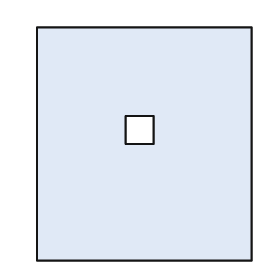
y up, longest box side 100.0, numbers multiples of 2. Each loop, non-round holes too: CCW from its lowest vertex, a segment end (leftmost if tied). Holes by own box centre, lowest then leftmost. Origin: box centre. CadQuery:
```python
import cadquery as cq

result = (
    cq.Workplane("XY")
    .moveTo(-46.0, -50.0)
    .lineTo(46.0, -50.0)
    .lineTo(46.0, 50.0)
    .lineTo(-46.0, 50.0)
    .close()
    .moveTo(-8.0, 0.0)
    .lineTo(4.0, 0.0)
    .lineTo(4.0, 12.0)
    .lineTo(-8.0, 12.0)
    .close()
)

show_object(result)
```